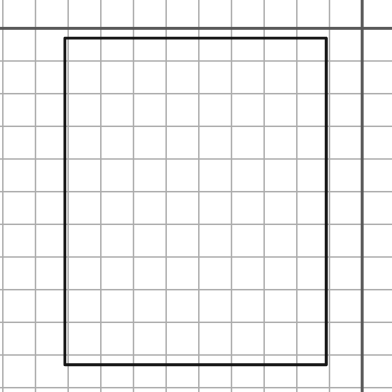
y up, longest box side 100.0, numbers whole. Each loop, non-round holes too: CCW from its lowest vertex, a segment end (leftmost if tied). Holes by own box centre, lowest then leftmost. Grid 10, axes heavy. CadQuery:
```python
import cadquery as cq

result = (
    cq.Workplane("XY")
    .moveTo(-91.0, -103.0)
    .lineTo(-11.0, -103.0)
    .lineTo(-11.0, -3.0)
    .lineTo(-91.0, -3.0)
    .close()
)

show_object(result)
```